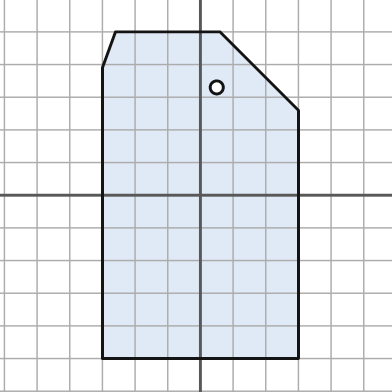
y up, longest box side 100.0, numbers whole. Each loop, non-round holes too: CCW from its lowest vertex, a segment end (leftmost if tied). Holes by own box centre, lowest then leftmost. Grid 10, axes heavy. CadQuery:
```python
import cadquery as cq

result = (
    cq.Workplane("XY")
    .moveTo(-30.0, -50.0)
    .lineTo(30.0, -50.0)
    .lineTo(30.0, 26.0)
    .lineTo(6.0, 50.0)
    .lineTo(-26.0, 50.0)
    .lineTo(-30.0, 39.0)
    .close()
    .moveTo(5.0, 33.0)
    .circle(2.0)
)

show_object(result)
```